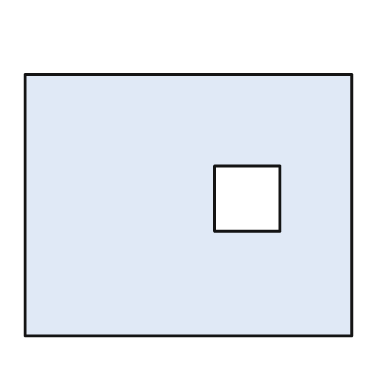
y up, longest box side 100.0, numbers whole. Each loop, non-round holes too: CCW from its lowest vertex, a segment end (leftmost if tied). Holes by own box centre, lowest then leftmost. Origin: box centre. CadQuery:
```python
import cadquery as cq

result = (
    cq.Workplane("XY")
    .moveTo(-50.0, -40.0)
    .lineTo(50.0, -40.0)
    .lineTo(50.0, 40.0)
    .lineTo(-50.0, 40.0)
    .close()
    .moveTo(8.0, -8.0)
    .lineTo(28.0, -8.0)
    .lineTo(28.0, 12.0)
    .lineTo(8.0, 12.0)
    .close()
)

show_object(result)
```